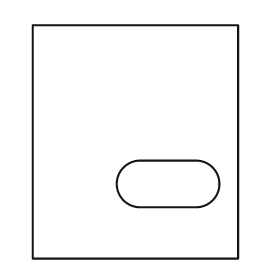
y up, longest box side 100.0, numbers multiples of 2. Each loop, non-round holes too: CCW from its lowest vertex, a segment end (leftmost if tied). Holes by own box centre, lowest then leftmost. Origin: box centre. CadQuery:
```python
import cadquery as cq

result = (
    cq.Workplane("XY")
    .moveTo(-44.0, -50.0)
    .lineTo(44.0, -50.0)
    .lineTo(44.0, 50.0)
    .lineTo(-44.0, 50.0)
    .close()
    .moveTo(2.0, -28.0)
    .lineTo(26.0, -28.0)
    .threePointArc((36.0, -18.0), (26.0, -8.0))
    .lineTo(2.0, -8.0)
    .threePointArc((-8.0, -18.0), (2.0, -28.0))
    .close()
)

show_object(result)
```